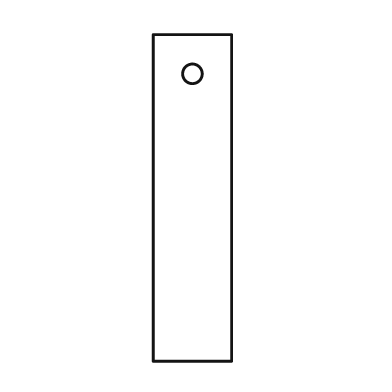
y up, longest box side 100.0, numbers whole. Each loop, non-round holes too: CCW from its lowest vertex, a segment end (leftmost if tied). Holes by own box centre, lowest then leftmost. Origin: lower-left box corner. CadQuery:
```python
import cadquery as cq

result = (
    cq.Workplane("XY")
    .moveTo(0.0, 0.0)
    .lineTo(24.0, 0.0)
    .lineTo(24.0, 100.0)
    .lineTo(0.0, 100.0)
    .close()
    .moveTo(12.0, 88.0)
    .circle(3.0)
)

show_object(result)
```